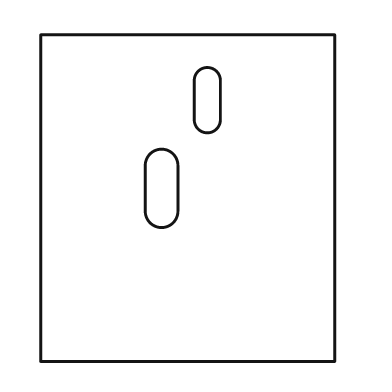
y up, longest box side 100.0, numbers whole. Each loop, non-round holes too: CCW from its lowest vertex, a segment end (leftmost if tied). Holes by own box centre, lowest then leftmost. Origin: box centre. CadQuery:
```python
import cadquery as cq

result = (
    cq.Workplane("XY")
    .moveTo(-45.0, -50.0)
    .lineTo(45.0, -50.0)
    .lineTo(45.0, 50.0)
    .lineTo(-45.0, 50.0)
    .close()
    .moveTo(-13.0, -4.0)
    .threePointArc((-8.0, -9.0), (-3.0, -4.0))
    .lineTo(-3.0, 10.0)
    .threePointArc((-8.0, 15.0), (-13.0, 10.0))
    .close()
    .moveTo(2.0, 24.0)
    .threePointArc((6.0, 20.0), (10.0, 24.0))
    .lineTo(10.0, 36.0)
    .threePointArc((6.0, 40.0), (2.0, 36.0))
    .close()
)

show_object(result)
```